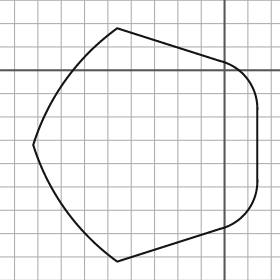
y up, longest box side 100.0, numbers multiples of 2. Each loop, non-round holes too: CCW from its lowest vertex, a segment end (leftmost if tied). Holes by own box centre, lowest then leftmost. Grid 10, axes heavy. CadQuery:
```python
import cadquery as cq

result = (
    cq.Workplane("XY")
    .moveTo(-46.0, -82.0)
    .lineTo(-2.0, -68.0)
    .threePointArc((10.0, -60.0), (14.0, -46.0))
    .lineTo(14.0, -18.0)
    .threePointArc((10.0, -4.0), (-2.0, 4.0))
    .lineTo(-46.0, 18.0)
    .threePointArc((-68.0, -4.0), (-82.0, -32.0))
    .threePointArc((-68.0, -60.0), (-46.0, -82.0))
    .close()
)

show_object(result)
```